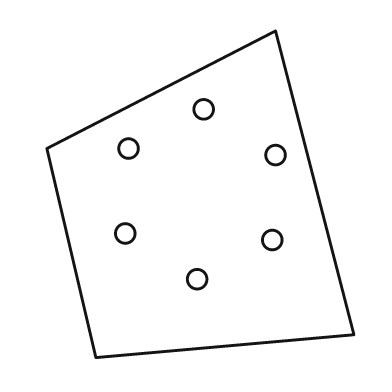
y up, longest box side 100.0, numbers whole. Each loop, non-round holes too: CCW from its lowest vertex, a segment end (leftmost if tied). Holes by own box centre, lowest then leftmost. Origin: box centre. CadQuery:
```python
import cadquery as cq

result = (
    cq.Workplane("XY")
    .moveTo(-32.0, -50.0)
    .lineTo(47.0, -43.0)
    .lineTo(23.0, 50.0)
    .lineTo(-47.0, 14.0)
    .close()
    .moveTo(-1.0, -26.0)
    .circle(3.0)
    .moveTo(22.0, -14.0)
    .circle(3.0)
    .moveTo(-23.0, -12.0)
    .circle(3.0)
    .moveTo(23.0, 12.0)
    .circle(3.0)
    .moveTo(-22.0, 14.0)
    .circle(3.0)
    .moveTo(1.0, 26.0)
    .circle(3.0)
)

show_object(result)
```